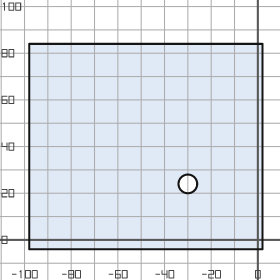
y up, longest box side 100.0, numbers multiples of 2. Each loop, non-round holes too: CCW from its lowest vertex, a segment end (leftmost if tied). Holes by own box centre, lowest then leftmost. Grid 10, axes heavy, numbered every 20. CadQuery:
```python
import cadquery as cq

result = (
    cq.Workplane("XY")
    .moveTo(-98.0, -4.0)
    .lineTo(2.0, -4.0)
    .lineTo(2.0, 84.0)
    .lineTo(-98.0, 84.0)
    .close()
    .moveTo(-30.0, 24.0)
    .circle(4.0)
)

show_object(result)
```